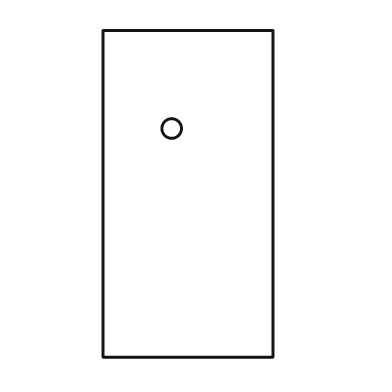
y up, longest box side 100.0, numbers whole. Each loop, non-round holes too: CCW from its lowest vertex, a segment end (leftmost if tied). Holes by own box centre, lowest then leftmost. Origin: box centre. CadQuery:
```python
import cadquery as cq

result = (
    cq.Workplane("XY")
    .moveTo(-26.0, -50.0)
    .lineTo(26.0, -50.0)
    .lineTo(26.0, 50.0)
    .lineTo(-26.0, 50.0)
    .close()
    .moveTo(-5.0, 20.0)
    .circle(3.0)
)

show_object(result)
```